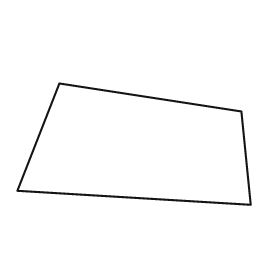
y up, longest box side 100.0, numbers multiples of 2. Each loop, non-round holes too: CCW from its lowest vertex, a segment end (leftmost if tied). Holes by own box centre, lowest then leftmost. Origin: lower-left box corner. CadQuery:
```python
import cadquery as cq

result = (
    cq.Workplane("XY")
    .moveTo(100.0, 0.0)
    .lineTo(96.0, 40.0)
    .lineTo(18.0, 52.0)
    .lineTo(0.0, 6.0)
    .close()
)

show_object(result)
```